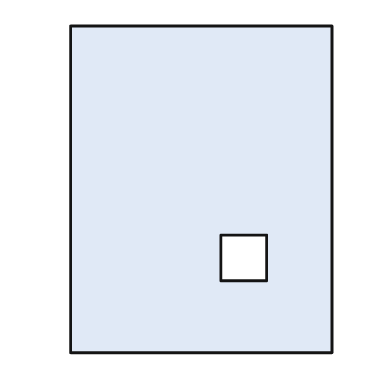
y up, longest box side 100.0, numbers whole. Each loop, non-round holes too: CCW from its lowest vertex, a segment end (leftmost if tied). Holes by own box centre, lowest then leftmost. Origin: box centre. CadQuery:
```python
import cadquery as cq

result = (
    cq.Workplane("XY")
    .moveTo(-40.0, -50.0)
    .lineTo(40.0, -50.0)
    .lineTo(40.0, 50.0)
    .lineTo(-40.0, 50.0)
    .close()
    .moveTo(6.0, -28.0)
    .lineTo(20.0, -28.0)
    .lineTo(20.0, -14.0)
    .lineTo(6.0, -14.0)
    .close()
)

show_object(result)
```